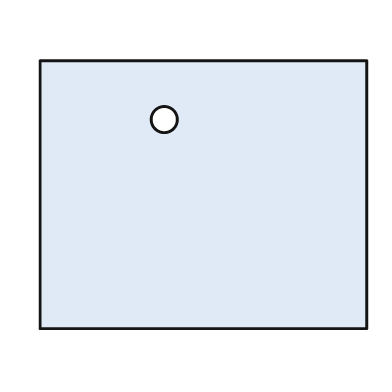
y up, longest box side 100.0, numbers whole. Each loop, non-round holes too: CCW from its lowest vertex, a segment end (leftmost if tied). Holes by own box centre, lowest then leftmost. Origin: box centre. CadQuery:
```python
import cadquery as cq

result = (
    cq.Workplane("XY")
    .moveTo(-50.0, -41.0)
    .lineTo(50.0, -41.0)
    .lineTo(50.0, 41.0)
    .lineTo(-50.0, 41.0)
    .close()
    .moveTo(-12.0, 23.0)
    .circle(4.0)
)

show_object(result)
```